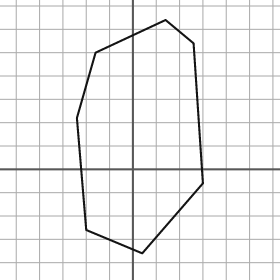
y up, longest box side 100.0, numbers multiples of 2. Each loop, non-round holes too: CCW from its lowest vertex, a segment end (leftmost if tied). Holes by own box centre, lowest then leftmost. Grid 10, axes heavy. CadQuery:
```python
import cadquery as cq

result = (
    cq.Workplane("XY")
    .moveTo(4.0, -36.0)
    .lineTo(30.0, -6.0)
    .lineTo(26.0, 54.0)
    .lineTo(14.0, 64.0)
    .lineTo(-16.0, 50.0)
    .lineTo(-24.0, 22.0)
    .lineTo(-20.0, -26.0)
    .close()
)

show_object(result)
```